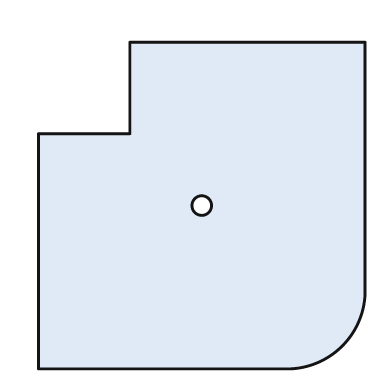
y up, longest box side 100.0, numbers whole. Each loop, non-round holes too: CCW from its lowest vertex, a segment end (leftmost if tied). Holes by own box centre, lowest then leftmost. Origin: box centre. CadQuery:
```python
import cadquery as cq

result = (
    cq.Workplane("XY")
    .moveTo(-50.0, -50.0)
    .lineTo(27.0, -50.0)
    .threePointArc((43.0, -43.0), (50.0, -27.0))
    .lineTo(50.0, 50.0)
    .lineTo(-22.0, 50.0)
    .lineTo(-22.0, 22.0)
    .lineTo(-50.0, 22.0)
    .close()
    .moveTo(0.0, 0.0)
    .circle(3.0)
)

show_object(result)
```